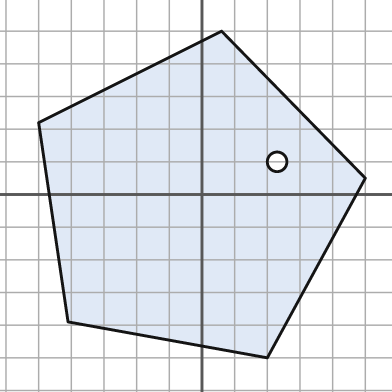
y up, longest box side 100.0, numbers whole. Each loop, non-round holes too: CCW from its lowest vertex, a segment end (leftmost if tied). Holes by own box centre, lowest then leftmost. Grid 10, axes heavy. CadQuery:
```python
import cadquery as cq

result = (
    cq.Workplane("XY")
    .moveTo(20.0, -50.0)
    .lineTo(50.0, 5.0)
    .lineTo(6.0, 50.0)
    .lineTo(-50.0, 22.0)
    .lineTo(-41.0, -39.0)
    .close()
    .moveTo(23.0, 10.0)
    .circle(3.0)
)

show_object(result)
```